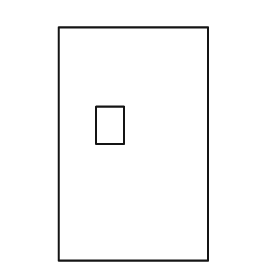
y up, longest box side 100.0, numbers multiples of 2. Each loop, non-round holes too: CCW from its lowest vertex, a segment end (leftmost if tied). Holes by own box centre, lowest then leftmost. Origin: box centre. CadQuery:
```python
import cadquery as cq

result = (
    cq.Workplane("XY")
    .moveTo(-32.0, -50.0)
    .lineTo(32.0, -50.0)
    .lineTo(32.0, 50.0)
    .lineTo(-32.0, 50.0)
    .close()
    .moveTo(-16.0, 0.0)
    .lineTo(-4.0, 0.0)
    .lineTo(-4.0, 16.0)
    .lineTo(-16.0, 16.0)
    .close()
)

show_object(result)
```